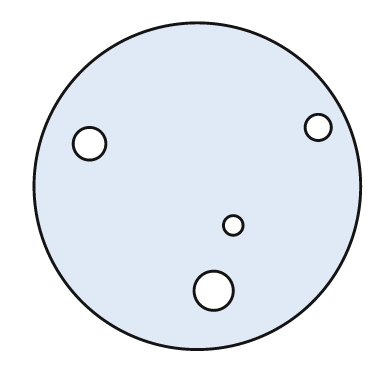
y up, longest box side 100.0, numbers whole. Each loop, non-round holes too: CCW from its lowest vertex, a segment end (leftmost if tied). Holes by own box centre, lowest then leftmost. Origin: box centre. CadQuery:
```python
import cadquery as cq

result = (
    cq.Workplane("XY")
    .moveTo(0.0, 0.0)
    .circle(50.0)
    .moveTo(5.0, -32.0)
    .circle(6.0)
    .moveTo(11.0, -12.0)
    .circle(3.0)
    .moveTo(-33.0, 13.0)
    .circle(5.0)
    .moveTo(37.0, 18.0)
    .circle(4.0)
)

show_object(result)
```